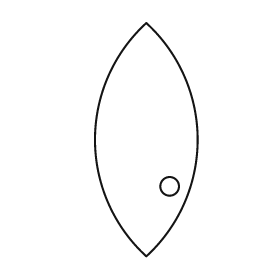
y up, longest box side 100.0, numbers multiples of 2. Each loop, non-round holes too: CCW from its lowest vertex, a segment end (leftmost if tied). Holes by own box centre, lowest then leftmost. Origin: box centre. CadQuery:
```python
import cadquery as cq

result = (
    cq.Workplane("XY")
    .moveTo(0.0, -50.0)
    .threePointArc((22.0, 0.0), (0.0, 50.0))
    .threePointArc((-22.0, 0.0), (0.0, -50.0))
    .close()
    .moveTo(10.0, -20.0)
    .circle(4.0)
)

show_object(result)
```